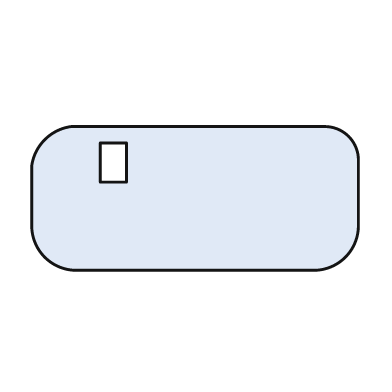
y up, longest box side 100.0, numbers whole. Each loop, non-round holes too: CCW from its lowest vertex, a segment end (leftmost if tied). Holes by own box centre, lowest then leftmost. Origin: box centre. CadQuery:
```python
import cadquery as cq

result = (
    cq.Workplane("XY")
    .moveTo(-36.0, -22.0)
    .lineTo(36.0, -22.0)
    .threePointArc((46.0, -18.0), (50.0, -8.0))
    .lineTo(50.0, 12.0)
    .threePointArc((47.0, 19.0), (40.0, 22.0))
    .lineTo(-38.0, 22.0)
    .threePointArc((-46.0, 18.0), (-50.0, 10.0))
    .lineTo(-50.0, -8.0)
    .threePointArc((-46.0, -18.0), (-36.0, -22.0))
    .close()
    .moveTo(-29.0, 5.0)
    .lineTo(-21.0, 5.0)
    .lineTo(-21.0, 17.0)
    .lineTo(-29.0, 17.0)
    .close()
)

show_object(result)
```